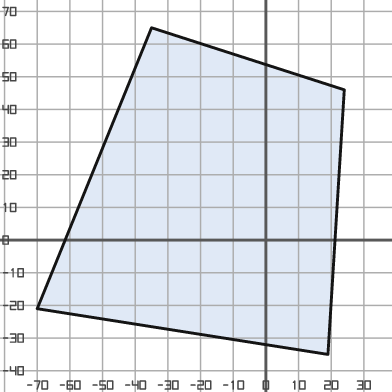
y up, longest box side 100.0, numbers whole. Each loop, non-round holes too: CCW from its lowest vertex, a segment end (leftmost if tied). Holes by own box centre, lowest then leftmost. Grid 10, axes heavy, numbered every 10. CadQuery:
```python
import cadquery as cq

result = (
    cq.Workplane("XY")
    .moveTo(19.0, -35.0)
    .lineTo(24.0, 46.0)
    .lineTo(-35.0, 65.0)
    .lineTo(-70.0, -21.0)
    .close()
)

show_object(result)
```